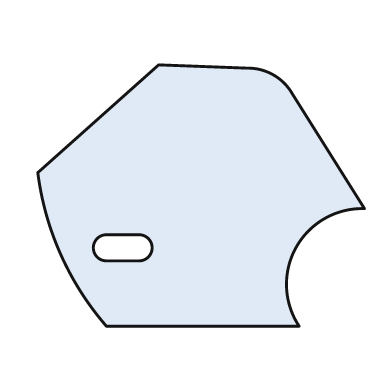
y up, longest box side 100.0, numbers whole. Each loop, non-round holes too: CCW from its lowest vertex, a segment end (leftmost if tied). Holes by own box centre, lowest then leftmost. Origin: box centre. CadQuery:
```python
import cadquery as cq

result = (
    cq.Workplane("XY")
    .moveTo(-29.0, -40.0)
    .lineTo(30.0, -40.0)
    .threePointArc((29.0, -16.0), (50.0, -4.0))
    .lineTo(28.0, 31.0)
    .threePointArc((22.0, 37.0), (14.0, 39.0))
    .lineTo(-13.0, 40.0)
    .lineTo(-50.0, 7.0)
    .threePointArc((-43.0, -18.0), (-29.0, -40.0))
    .close()
    .moveTo(-29.0, -20.0)
    .lineTo(-19.0, -20.0)
    .threePointArc((-15.0, -16.0), (-19.0, -12.0))
    .lineTo(-29.0, -12.0)
    .threePointArc((-33.0, -16.0), (-29.0, -20.0))
    .close()
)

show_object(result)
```